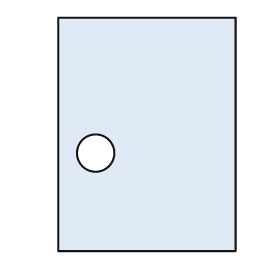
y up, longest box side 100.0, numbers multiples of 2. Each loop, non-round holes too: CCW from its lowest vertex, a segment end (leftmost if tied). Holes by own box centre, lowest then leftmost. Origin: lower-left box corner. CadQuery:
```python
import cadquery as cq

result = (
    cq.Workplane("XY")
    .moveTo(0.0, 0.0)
    .lineTo(76.0, 0.0)
    .lineTo(76.0, 100.0)
    .lineTo(0.0, 100.0)
    .close()
    .moveTo(16.0, 42.0)
    .circle(8.0)
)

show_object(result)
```